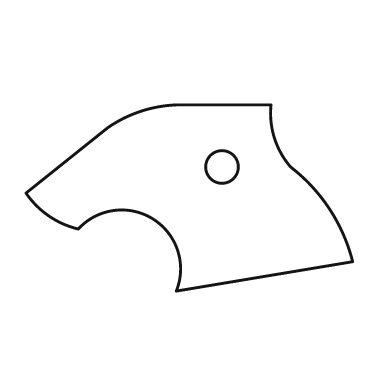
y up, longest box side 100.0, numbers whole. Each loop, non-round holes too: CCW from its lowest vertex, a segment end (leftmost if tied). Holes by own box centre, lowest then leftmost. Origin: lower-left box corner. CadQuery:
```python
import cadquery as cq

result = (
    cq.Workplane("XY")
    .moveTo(46.0, 0.0)
    .lineTo(100.0, 9.0)
    .threePointArc((93.0, 25.0), (81.0, 38.0))
    .threePointArc((76.0, 47.0), (75.0, 57.0))
    .lineTo(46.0, 57.0)
    .threePointArc((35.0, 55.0), (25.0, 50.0))
    .lineTo(0.0, 30.0)
    .threePointArc((7.0, 23.0), (16.0, 19.0))
    .threePointArc((39.0, 22.0), (46.0, 0.0))
    .close()
    .moveTo(60.0, 38.0)
    .circle(5.0)
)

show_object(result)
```